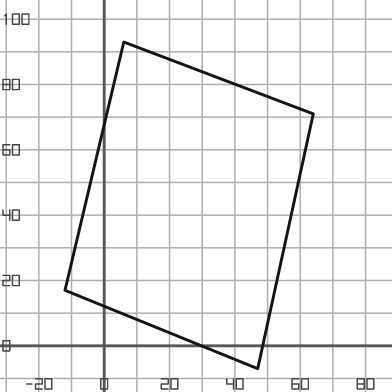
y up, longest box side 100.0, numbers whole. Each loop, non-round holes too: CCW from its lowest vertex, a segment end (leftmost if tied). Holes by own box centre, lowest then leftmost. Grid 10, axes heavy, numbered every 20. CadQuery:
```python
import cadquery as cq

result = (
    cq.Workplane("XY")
    .moveTo(47.0, -7.0)
    .lineTo(64.0, 71.0)
    .lineTo(6.0, 93.0)
    .lineTo(-12.0, 17.0)
    .close()
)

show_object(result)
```